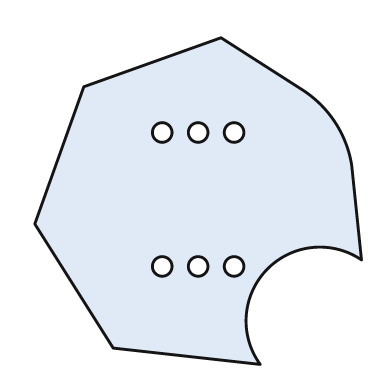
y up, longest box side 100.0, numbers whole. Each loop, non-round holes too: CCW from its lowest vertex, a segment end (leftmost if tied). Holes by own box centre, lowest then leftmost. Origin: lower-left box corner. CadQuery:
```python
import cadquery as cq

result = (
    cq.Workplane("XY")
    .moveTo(69.0, 0.0)
    .threePointArc((71.0, 29.0), (100.0, 32.0))
    .lineTo(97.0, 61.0)
    .threePointArc((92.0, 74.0), (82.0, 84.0))
    .lineTo(57.0, 100.0)
    .lineTo(15.0, 85.0)
    .lineTo(0.0, 43.0)
    .lineTo(24.0, 5.0)
    .close()
    .moveTo(39.0, 30.0)
    .circle(3.0)
    .moveTo(50.0, 30.0)
    .circle(3.0)
    .moveTo(61.0, 30.0)
    .circle(3.0)
    .moveTo(39.0, 71.0)
    .circle(3.0)
    .moveTo(50.0, 71.0)
    .circle(3.0)
    .moveTo(61.0, 71.0)
    .circle(3.0)
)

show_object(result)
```